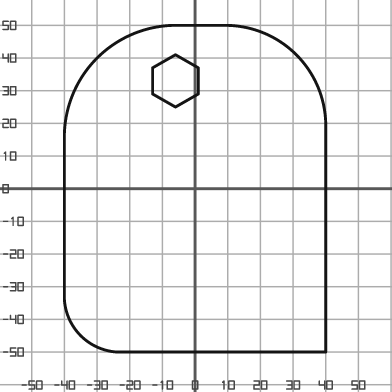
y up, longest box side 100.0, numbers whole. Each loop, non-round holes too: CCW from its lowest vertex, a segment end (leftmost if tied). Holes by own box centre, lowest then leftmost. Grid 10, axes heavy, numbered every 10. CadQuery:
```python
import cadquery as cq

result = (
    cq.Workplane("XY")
    .moveTo(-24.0, -50.0)
    .lineTo(40.0, -50.0)
    .lineTo(40.0, 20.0)
    .threePointArc((31.0, 41.0), (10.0, 50.0))
    .lineTo(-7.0, 50.0)
    .threePointArc((-30.0, 40.0), (-40.0, 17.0))
    .lineTo(-40.0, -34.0)
    .threePointArc((-35.0, -45.0), (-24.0, -50.0))
    .close()
    .moveTo(-6.0, 25.0)
    .lineTo(1.0, 29.0)
    .lineTo(1.0, 37.0)
    .lineTo(-6.0, 41.0)
    .lineTo(-13.0, 37.0)
    .lineTo(-13.0, 29.0)
    .close()
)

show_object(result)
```